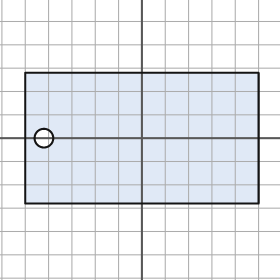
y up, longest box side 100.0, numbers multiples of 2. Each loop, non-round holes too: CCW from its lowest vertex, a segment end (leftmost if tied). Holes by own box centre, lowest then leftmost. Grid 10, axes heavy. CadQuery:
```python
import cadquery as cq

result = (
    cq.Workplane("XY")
    .moveTo(-50.0, -28.0)
    .lineTo(50.0, -28.0)
    .lineTo(50.0, 28.0)
    .lineTo(-50.0, 28.0)
    .close()
    .moveTo(-42.0, 0.0)
    .circle(4.0)
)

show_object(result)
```